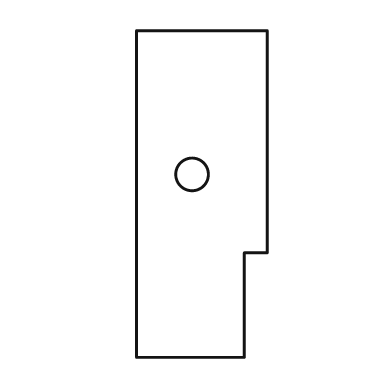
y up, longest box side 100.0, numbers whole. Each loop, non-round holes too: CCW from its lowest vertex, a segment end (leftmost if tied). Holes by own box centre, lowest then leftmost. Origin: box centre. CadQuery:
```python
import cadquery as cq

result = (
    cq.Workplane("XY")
    .moveTo(-20.0, -50.0)
    .lineTo(13.0, -50.0)
    .lineTo(13.0, -18.0)
    .lineTo(20.0, -18.0)
    .lineTo(20.0, 50.0)
    .lineTo(-20.0, 50.0)
    .close()
    .moveTo(-3.0, 6.0)
    .circle(5.0)
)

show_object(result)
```